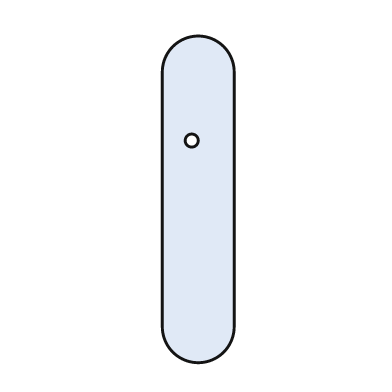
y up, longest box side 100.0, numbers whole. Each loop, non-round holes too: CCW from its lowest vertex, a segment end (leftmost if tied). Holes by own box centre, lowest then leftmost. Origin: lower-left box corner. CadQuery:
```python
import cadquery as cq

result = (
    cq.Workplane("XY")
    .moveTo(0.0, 11.0)
    .threePointArc((11.0, 0.0), (22.0, 11.0))
    .lineTo(22.0, 89.0)
    .threePointArc((11.0, 100.0), (0.0, 89.0))
    .close()
    .moveTo(9.0, 68.0)
    .circle(2.0)
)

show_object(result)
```